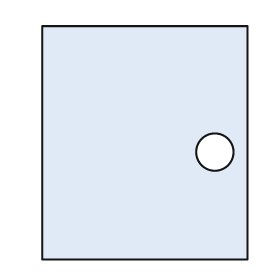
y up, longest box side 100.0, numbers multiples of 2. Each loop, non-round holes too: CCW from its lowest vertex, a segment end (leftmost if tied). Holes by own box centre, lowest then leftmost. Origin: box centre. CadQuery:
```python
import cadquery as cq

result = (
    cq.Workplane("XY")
    .moveTo(-44.0, -50.0)
    .lineTo(44.0, -50.0)
    .lineTo(44.0, 50.0)
    .lineTo(-44.0, 50.0)
    .close()
    .moveTo(30.0, -4.0)
    .circle(8.0)
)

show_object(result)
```